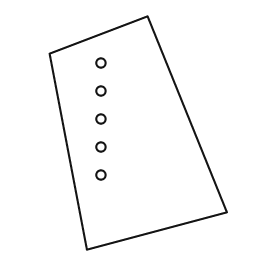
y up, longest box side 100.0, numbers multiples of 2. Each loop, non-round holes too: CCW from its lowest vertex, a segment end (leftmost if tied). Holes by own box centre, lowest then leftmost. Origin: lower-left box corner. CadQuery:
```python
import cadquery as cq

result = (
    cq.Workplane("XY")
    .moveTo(16.0, 0.0)
    .lineTo(76.0, 16.0)
    .lineTo(42.0, 100.0)
    .lineTo(0.0, 84.0)
    .close()
    .moveTo(22.0, 32.0)
    .circle(2.0)
    .moveTo(22.0, 44.0)
    .circle(2.0)
    .moveTo(22.0, 56.0)
    .circle(2.0)
    .moveTo(22.0, 68.0)
    .circle(2.0)
    .moveTo(22.0, 80.0)
    .circle(2.0)
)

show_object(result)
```